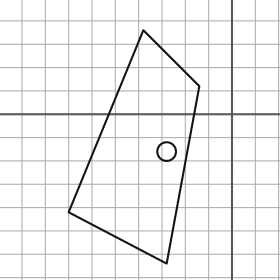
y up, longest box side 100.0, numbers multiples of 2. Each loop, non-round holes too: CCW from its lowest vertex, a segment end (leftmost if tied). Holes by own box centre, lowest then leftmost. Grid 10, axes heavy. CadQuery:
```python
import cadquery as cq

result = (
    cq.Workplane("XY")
    .moveTo(-28.0, -64.0)
    .lineTo(-14.0, 12.0)
    .lineTo(-38.0, 36.0)
    .lineTo(-70.0, -42.0)
    .close()
    .moveTo(-28.0, -16.0)
    .circle(4.0)
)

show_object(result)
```